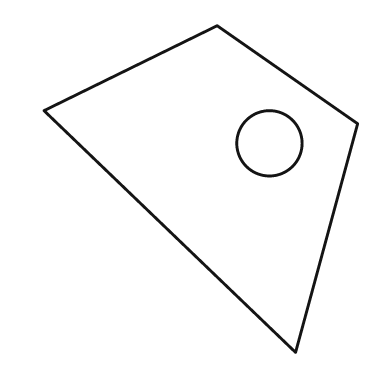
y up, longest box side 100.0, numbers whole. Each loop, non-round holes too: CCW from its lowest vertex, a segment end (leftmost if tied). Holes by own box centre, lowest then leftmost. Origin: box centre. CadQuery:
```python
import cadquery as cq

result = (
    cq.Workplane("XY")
    .moveTo(29.0, -50.0)
    .lineTo(48.0, 20.0)
    .lineTo(5.0, 50.0)
    .lineTo(-48.0, 24.0)
    .close()
    .moveTo(21.0, 14.0)
    .circle(10.0)
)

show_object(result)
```